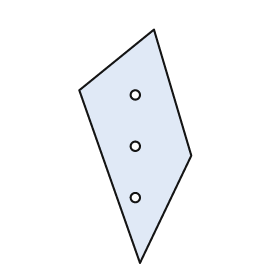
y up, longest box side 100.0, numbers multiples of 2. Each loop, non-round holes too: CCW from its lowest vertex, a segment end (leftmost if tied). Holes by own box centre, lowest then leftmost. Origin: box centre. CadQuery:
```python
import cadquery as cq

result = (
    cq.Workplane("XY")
    .moveTo(2.0, -50.0)
    .lineTo(24.0, -4.0)
    .lineTo(8.0, 50.0)
    .lineTo(-24.0, 24.0)
    .close()
    .moveTo(0.0, -22.0)
    .circle(2.0)
    .moveTo(0.0, 0.0)
    .circle(2.0)
    .moveTo(0.0, 22.0)
    .circle(2.0)
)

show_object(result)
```